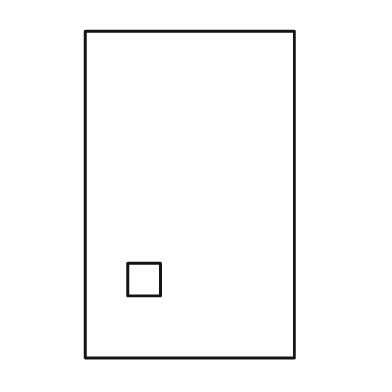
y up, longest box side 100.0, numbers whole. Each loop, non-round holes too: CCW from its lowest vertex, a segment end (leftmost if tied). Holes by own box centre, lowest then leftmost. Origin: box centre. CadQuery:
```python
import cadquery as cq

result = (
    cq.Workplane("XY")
    .moveTo(-32.0, -50.0)
    .lineTo(32.0, -50.0)
    .lineTo(32.0, 50.0)
    .lineTo(-32.0, 50.0)
    .close()
    .moveTo(-19.0, -31.0)
    .lineTo(-9.0, -31.0)
    .lineTo(-9.0, -21.0)
    .lineTo(-19.0, -21.0)
    .close()
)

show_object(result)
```